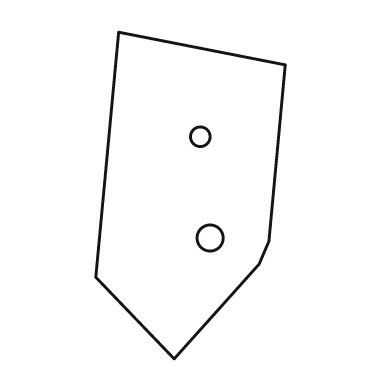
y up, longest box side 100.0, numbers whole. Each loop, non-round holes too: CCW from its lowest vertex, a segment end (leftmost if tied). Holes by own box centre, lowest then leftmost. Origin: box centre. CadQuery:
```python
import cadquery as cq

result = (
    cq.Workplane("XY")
    .moveTo(-5.0, -50.0)
    .lineTo(21.0, -21.0)
    .lineTo(24.0, -14.0)
    .lineTo(29.0, 40.0)
    .lineTo(-22.0, 50.0)
    .lineTo(-29.0, -25.0)
    .close()
    .moveTo(6.0, -13.0)
    .circle(4.0)
    .moveTo(3.0, 18.0)
    .circle(3.0)
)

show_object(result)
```